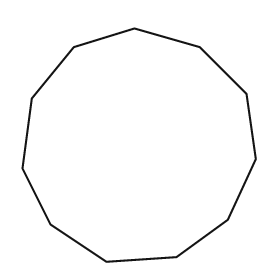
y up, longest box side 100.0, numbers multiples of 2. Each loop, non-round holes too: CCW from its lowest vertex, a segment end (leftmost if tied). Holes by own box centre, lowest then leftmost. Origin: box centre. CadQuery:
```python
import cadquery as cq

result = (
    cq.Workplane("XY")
    .moveTo(-14.0, -50.0)
    .lineTo(16.0, -48.0)
    .lineTo(38.0, -32.0)
    .lineTo(50.0, -6.0)
    .lineTo(46.0, 22.0)
    .lineTo(26.0, 42.0)
    .lineTo(-2.0, 50.0)
    .lineTo(-28.0, 42.0)
    .lineTo(-46.0, 20.0)
    .lineTo(-50.0, -10.0)
    .lineTo(-38.0, -34.0)
    .close()
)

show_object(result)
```